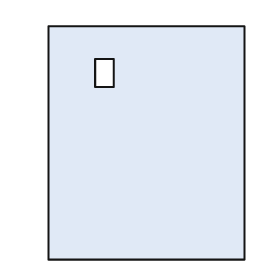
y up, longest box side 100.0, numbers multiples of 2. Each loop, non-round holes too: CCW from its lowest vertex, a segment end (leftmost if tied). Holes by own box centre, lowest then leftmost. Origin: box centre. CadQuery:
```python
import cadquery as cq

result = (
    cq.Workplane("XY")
    .moveTo(-42.0, -50.0)
    .lineTo(42.0, -50.0)
    .lineTo(42.0, 50.0)
    .lineTo(-42.0, 50.0)
    .close()
    .moveTo(-22.0, 24.0)
    .lineTo(-14.0, 24.0)
    .lineTo(-14.0, 36.0)
    .lineTo(-22.0, 36.0)
    .close()
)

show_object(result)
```